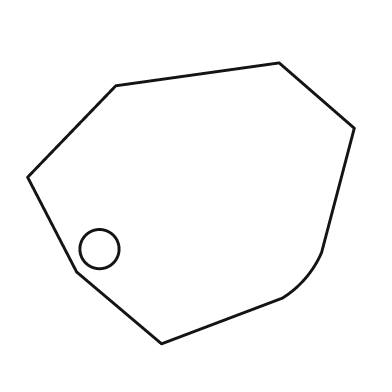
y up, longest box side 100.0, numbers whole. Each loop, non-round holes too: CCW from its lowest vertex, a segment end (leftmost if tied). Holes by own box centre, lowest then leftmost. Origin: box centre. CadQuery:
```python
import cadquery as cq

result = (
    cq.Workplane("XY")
    .moveTo(-9.0, -43.0)
    .lineTo(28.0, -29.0)
    .threePointArc((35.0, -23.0), (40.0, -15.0))
    .lineTo(50.0, 23.0)
    .lineTo(27.0, 43.0)
    .lineTo(-23.0, 36.0)
    .lineTo(-50.0, 8.0)
    .lineTo(-35.0, -21.0)
    .close()
    .moveTo(-28.0, -14.0)
    .circle(6.0)
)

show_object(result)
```